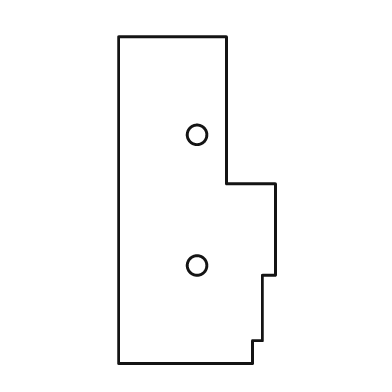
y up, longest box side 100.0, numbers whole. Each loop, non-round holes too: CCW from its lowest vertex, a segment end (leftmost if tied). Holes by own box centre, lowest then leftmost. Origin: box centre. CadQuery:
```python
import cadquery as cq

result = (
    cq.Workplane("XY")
    .moveTo(-24.0, -50.0)
    .lineTo(17.0, -50.0)
    .lineTo(17.0, -43.0)
    .lineTo(20.0, -43.0)
    .lineTo(20.0, -23.0)
    .lineTo(24.0, -23.0)
    .lineTo(24.0, 5.0)
    .lineTo(9.0, 5.0)
    .lineTo(9.0, 50.0)
    .lineTo(-24.0, 50.0)
    .close()
    .moveTo(0.0, -20.0)
    .circle(3.0)
    .moveTo(0.0, 20.0)
    .circle(3.0)
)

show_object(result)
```